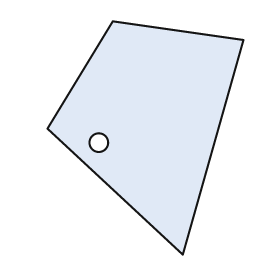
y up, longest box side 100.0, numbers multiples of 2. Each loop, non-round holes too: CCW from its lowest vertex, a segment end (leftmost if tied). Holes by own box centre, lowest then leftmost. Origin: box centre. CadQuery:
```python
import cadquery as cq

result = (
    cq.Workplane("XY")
    .moveTo(16.0, -50.0)
    .lineTo(42.0, 42.0)
    .lineTo(-14.0, 50.0)
    .lineTo(-42.0, 4.0)
    .close()
    .moveTo(-20.0, -2.0)
    .circle(4.0)
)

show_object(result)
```